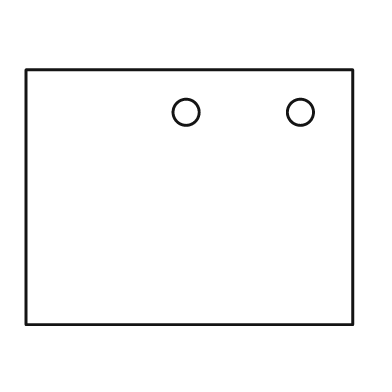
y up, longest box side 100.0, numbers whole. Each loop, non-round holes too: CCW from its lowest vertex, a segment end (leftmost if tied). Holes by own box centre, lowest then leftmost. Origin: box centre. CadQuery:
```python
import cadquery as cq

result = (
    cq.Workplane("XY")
    .moveTo(-50.0, -39.0)
    .lineTo(50.0, -39.0)
    .lineTo(50.0, 39.0)
    .lineTo(-50.0, 39.0)
    .close()
    .moveTo(-1.0, 26.0)
    .circle(4.0)
    .moveTo(34.0, 26.0)
    .circle(4.0)
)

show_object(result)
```